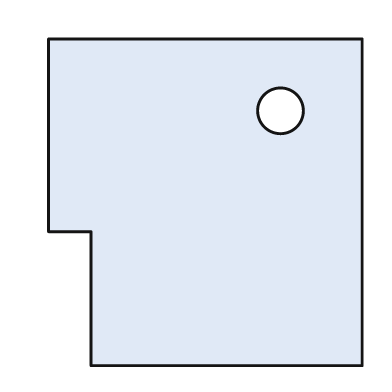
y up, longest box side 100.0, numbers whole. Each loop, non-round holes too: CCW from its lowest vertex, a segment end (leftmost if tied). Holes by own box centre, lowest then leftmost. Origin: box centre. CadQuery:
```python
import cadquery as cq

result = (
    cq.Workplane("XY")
    .moveTo(-35.0, -50.0)
    .lineTo(48.0, -50.0)
    .lineTo(48.0, 50.0)
    .lineTo(-48.0, 50.0)
    .lineTo(-48.0, -9.0)
    .lineTo(-35.0, -9.0)
    .close()
    .moveTo(23.0, 28.0)
    .circle(7.0)
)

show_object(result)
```